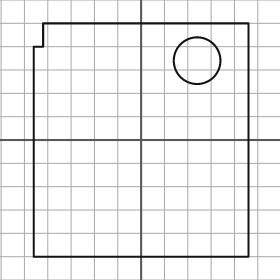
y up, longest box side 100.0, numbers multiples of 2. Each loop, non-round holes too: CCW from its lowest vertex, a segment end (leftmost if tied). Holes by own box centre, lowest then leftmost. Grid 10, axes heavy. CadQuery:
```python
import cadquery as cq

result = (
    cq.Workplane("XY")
    .moveTo(-46.0, -50.0)
    .lineTo(46.0, -50.0)
    .lineTo(46.0, 50.0)
    .lineTo(-42.0, 50.0)
    .lineTo(-42.0, 40.0)
    .lineTo(-46.0, 40.0)
    .close()
    .moveTo(24.0, 34.0)
    .circle(10.0)
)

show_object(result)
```